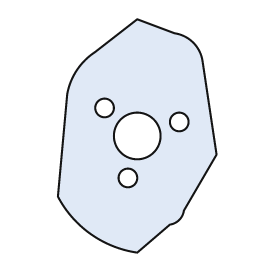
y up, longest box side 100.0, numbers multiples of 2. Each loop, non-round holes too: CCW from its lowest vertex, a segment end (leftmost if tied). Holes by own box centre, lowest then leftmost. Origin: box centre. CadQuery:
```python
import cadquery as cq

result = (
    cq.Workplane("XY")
    .moveTo(0.0, -50.0)
    .lineTo(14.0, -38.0)
    .threePointArc((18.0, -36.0), (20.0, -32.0))
    .lineTo(34.0, -8.0)
    .lineTo(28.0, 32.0)
    .threePointArc((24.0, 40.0), (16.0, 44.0))
    .lineTo(0.0, 50.0)
    .lineTo(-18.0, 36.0)
    .threePointArc((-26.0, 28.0), (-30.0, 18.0))
    .lineTo(-34.0, -26.0)
    .threePointArc((-20.0, -42.0), (0.0, -50.0))
    .close()
    .moveTo(-4.0, -18.0)
    .circle(4.0)
    .moveTo(0.0, 0.0)
    .circle(10.0)
    .moveTo(18.0, 6.0)
    .circle(4.0)
    .moveTo(-14.0, 12.0)
    .circle(4.0)
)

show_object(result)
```